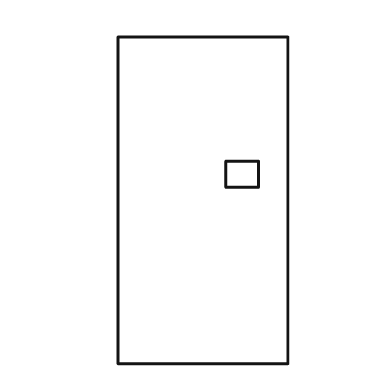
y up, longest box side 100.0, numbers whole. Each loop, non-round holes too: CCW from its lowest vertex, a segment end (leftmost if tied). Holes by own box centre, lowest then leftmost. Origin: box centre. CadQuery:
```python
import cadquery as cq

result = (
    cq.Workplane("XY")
    .moveTo(-26.0, -50.0)
    .lineTo(26.0, -50.0)
    .lineTo(26.0, 50.0)
    .lineTo(-26.0, 50.0)
    .close()
    .moveTo(7.0, 4.0)
    .lineTo(17.0, 4.0)
    .lineTo(17.0, 12.0)
    .lineTo(7.0, 12.0)
    .close()
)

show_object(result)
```